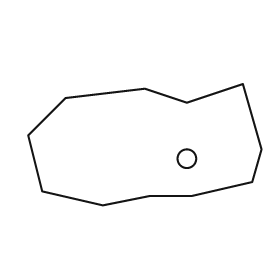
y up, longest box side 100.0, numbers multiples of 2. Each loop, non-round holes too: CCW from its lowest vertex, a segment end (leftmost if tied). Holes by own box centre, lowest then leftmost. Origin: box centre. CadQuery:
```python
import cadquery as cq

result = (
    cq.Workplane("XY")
    .moveTo(-18.0, -26.0)
    .lineTo(2.0, -22.0)
    .lineTo(20.0, -22.0)
    .lineTo(46.0, -16.0)
    .lineTo(50.0, -2.0)
    .lineTo(42.0, 26.0)
    .lineTo(18.0, 18.0)
    .lineTo(0.0, 24.0)
    .lineTo(-34.0, 20.0)
    .lineTo(-50.0, 4.0)
    .lineTo(-44.0, -20.0)
    .close()
    .moveTo(18.0, -6.0)
    .circle(4.0)
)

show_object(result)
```